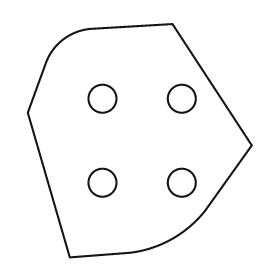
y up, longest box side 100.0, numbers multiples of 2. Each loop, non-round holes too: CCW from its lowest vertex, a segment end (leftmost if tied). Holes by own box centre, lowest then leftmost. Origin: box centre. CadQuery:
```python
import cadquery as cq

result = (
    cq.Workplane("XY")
    .moveTo(-30.0, -50.0)
    .lineTo(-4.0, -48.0)
    .threePointArc((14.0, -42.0), (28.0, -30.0))
    .lineTo(48.0, -2.0)
    .lineTo(14.0, 50.0)
    .lineTo(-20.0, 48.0)
    .threePointArc((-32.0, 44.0), (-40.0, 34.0))
    .lineTo(-48.0, 12.0)
    .close()
    .moveTo(-16.0, -18.0)
    .circle(6.0)
    .moveTo(18.0, -18.0)
    .circle(6.0)
    .moveTo(-16.0, 18.0)
    .circle(6.0)
    .moveTo(18.0, 18.0)
    .circle(6.0)
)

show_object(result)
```